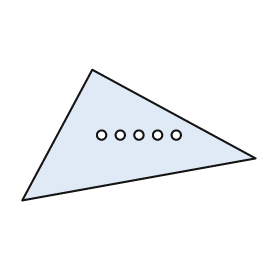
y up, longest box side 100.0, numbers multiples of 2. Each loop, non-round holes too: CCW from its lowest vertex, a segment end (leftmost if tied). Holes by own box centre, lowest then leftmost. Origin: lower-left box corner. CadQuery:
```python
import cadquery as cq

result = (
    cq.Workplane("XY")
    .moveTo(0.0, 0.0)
    .lineTo(100.0, 18.0)
    .lineTo(30.0, 56.0)
    .close()
    .moveTo(34.0, 28.0)
    .circle(2.0)
    .moveTo(42.0, 28.0)
    .circle(2.0)
    .moveTo(50.0, 28.0)
    .circle(2.0)
    .moveTo(58.0, 28.0)
    .circle(2.0)
    .moveTo(66.0, 28.0)
    .circle(2.0)
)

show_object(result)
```